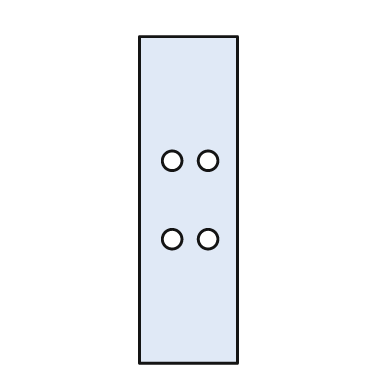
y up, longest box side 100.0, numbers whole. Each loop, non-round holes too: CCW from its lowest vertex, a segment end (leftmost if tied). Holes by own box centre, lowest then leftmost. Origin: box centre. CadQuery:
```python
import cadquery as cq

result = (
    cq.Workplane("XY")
    .moveTo(-15.0, -50.0)
    .lineTo(15.0, -50.0)
    .lineTo(15.0, 50.0)
    .lineTo(-15.0, 50.0)
    .close()
    .moveTo(-5.0, -12.0)
    .circle(3.0)
    .moveTo(6.0, -12.0)
    .circle(3.0)
    .moveTo(-5.0, 12.0)
    .circle(3.0)
    .moveTo(6.0, 12.0)
    .circle(3.0)
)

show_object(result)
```